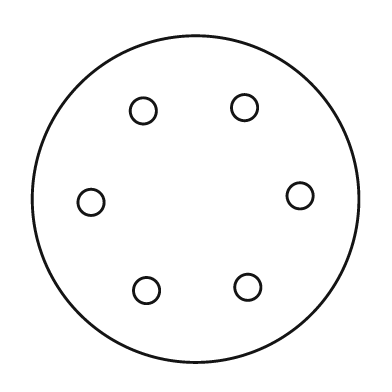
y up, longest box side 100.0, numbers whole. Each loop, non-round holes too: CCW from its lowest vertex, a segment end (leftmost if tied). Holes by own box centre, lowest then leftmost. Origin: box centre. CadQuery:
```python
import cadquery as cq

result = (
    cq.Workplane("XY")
    .moveTo(0.0, 0.0)
    .circle(50.0)
    .moveTo(-15.0, -28.0)
    .circle(4.0)
    .moveTo(16.0, -27.0)
    .circle(4.0)
    .moveTo(-32.0, -1.0)
    .circle(4.0)
    .moveTo(32.0, 1.0)
    .circle(4.0)
    .moveTo(-16.0, 27.0)
    .circle(4.0)
    .moveTo(15.0, 28.0)
    .circle(4.0)
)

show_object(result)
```